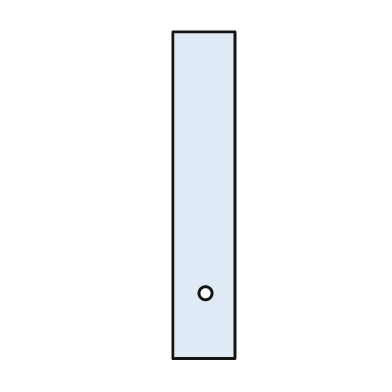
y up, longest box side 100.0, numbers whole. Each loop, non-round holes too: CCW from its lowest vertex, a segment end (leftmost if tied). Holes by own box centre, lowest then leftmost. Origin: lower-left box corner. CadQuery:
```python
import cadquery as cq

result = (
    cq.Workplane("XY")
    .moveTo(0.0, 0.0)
    .lineTo(19.0, 0.0)
    .lineTo(19.0, 100.0)
    .lineTo(0.0, 100.0)
    .close()
    .moveTo(10.0, 20.0)
    .circle(2.0)
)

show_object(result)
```